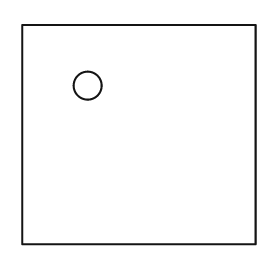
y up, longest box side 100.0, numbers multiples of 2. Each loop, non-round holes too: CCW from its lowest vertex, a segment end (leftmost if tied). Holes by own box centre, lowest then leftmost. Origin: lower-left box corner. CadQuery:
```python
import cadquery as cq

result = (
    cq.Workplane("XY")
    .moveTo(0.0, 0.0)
    .lineTo(100.0, 0.0)
    .lineTo(100.0, 94.0)
    .lineTo(0.0, 94.0)
    .close()
    .moveTo(28.0, 68.0)
    .circle(6.0)
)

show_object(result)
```